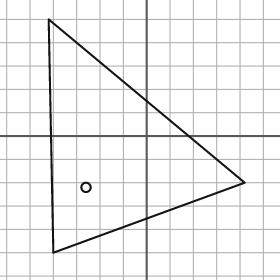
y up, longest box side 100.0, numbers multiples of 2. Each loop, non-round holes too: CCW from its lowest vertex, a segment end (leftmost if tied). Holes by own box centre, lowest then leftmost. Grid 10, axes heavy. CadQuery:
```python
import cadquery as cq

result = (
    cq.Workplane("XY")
    .moveTo(-40.0, -50.0)
    .lineTo(42.0, -20.0)
    .lineTo(-42.0, 50.0)
    .close()
    .moveTo(-26.0, -22.0)
    .circle(2.0)
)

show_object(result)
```